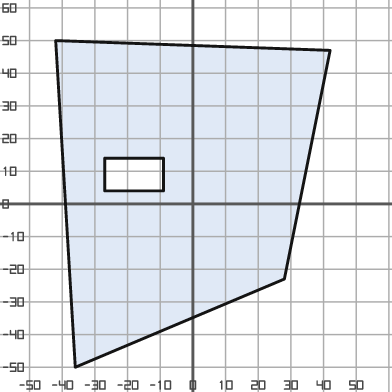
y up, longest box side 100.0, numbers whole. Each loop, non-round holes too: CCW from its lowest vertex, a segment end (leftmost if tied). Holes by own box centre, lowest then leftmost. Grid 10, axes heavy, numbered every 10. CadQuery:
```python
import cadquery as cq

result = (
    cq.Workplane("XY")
    .moveTo(-36.0, -50.0)
    .lineTo(28.0, -23.0)
    .lineTo(42.0, 47.0)
    .lineTo(-42.0, 50.0)
    .close()
    .moveTo(-27.0, 4.0)
    .lineTo(-9.0, 4.0)
    .lineTo(-9.0, 14.0)
    .lineTo(-27.0, 14.0)
    .close()
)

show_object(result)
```